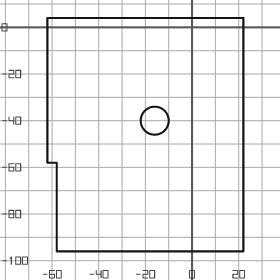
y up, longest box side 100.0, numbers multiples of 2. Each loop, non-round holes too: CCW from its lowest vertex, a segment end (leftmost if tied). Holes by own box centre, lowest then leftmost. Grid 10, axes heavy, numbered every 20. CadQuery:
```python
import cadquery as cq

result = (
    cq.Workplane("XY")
    .moveTo(-58.0, -96.0)
    .lineTo(22.0, -96.0)
    .lineTo(22.0, 4.0)
    .lineTo(-62.0, 4.0)
    .lineTo(-62.0, -58.0)
    .lineTo(-58.0, -58.0)
    .close()
    .moveTo(-16.0, -40.0)
    .circle(6.0)
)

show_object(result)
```